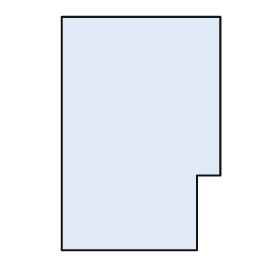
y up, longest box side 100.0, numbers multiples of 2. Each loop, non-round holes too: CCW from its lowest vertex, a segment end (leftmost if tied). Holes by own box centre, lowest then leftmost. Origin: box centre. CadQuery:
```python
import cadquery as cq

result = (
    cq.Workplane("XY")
    .moveTo(-34.0, -50.0)
    .lineTo(24.0, -50.0)
    .lineTo(24.0, -18.0)
    .lineTo(34.0, -18.0)
    .lineTo(34.0, 50.0)
    .lineTo(-34.0, 50.0)
    .close()
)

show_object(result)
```